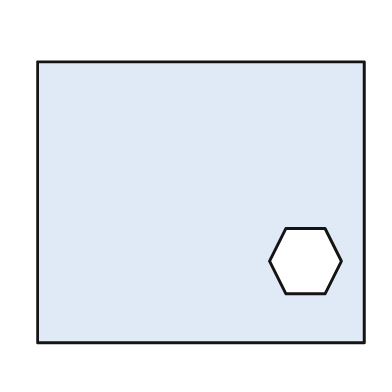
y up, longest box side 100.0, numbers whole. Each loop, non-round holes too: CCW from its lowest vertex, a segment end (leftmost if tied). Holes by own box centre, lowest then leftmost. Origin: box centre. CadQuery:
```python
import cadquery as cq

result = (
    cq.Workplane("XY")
    .moveTo(-50.0, -43.0)
    .lineTo(50.0, -43.0)
    .lineTo(50.0, 43.0)
    .lineTo(-50.0, 43.0)
    .close()
    .moveTo(26.0, -28.0)
    .lineTo(38.0, -28.0)
    .lineTo(43.0, -18.0)
    .lineTo(38.0, -8.0)
    .lineTo(26.0, -8.0)
    .lineTo(21.0, -18.0)
    .close()
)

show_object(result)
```